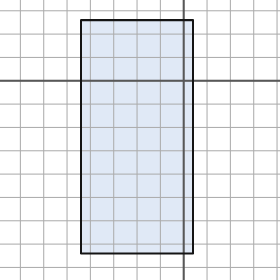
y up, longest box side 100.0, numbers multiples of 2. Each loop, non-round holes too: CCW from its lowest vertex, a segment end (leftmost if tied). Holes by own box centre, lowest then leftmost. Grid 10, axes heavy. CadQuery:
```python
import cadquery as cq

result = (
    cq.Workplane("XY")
    .moveTo(-44.0, -74.0)
    .lineTo(4.0, -74.0)
    .lineTo(4.0, 26.0)
    .lineTo(-44.0, 26.0)
    .close()
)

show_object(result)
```